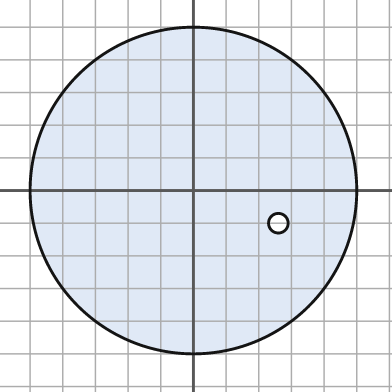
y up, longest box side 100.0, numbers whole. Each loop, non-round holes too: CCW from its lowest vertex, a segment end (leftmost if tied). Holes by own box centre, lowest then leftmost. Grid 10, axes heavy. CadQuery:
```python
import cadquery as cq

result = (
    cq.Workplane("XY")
    .moveTo(0.0, 0.0)
    .circle(50.0)
    .moveTo(26.0, -10.0)
    .circle(3.0)
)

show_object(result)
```